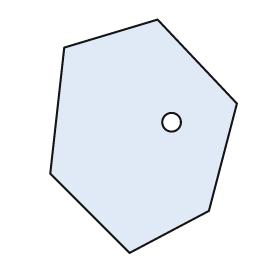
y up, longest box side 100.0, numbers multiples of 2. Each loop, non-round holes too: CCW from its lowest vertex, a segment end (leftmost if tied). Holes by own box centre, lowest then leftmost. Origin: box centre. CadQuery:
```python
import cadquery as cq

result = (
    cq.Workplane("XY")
    .moveTo(-6.0, -50.0)
    .lineTo(28.0, -32.0)
    .lineTo(40.0, 14.0)
    .lineTo(6.0, 50.0)
    .lineTo(-34.0, 38.0)
    .lineTo(-40.0, -16.0)
    .close()
    .moveTo(12.0, 6.0)
    .circle(4.0)
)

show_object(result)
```